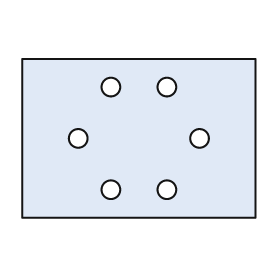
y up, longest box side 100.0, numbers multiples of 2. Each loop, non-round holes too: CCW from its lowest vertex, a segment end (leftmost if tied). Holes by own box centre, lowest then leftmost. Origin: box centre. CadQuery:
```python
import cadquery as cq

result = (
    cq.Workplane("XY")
    .moveTo(-50.0, -34.0)
    .lineTo(50.0, -34.0)
    .lineTo(50.0, 34.0)
    .lineTo(-50.0, 34.0)
    .close()
    .moveTo(-12.0, -22.0)
    .circle(4.0)
    .moveTo(12.0, -22.0)
    .circle(4.0)
    .moveTo(-26.0, 0.0)
    .circle(4.0)
    .moveTo(26.0, 0.0)
    .circle(4.0)
    .moveTo(-12.0, 22.0)
    .circle(4.0)
    .moveTo(12.0, 22.0)
    .circle(4.0)
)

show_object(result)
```